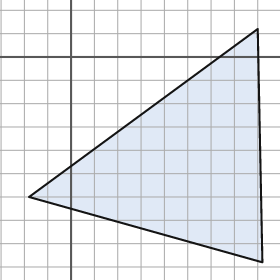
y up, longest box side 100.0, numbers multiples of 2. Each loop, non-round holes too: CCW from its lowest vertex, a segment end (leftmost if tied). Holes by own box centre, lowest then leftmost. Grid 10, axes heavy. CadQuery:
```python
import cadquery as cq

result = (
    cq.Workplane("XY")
    .moveTo(82.0, -88.0)
    .lineTo(80.0, 12.0)
    .lineTo(-18.0, -60.0)
    .close()
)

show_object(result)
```